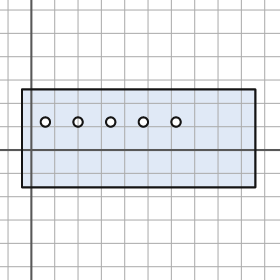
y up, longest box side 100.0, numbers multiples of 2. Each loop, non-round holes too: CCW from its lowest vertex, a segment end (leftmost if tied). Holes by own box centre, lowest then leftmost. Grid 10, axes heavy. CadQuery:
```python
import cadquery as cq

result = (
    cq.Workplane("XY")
    .moveTo(-4.0, -16.0)
    .lineTo(96.0, -16.0)
    .lineTo(96.0, 26.0)
    .lineTo(-4.0, 26.0)
    .close()
    .moveTo(6.0, 12.0)
    .circle(2.0)
    .moveTo(20.0, 12.0)
    .circle(2.0)
    .moveTo(34.0, 12.0)
    .circle(2.0)
    .moveTo(48.0, 12.0)
    .circle(2.0)
    .moveTo(62.0, 12.0)
    .circle(2.0)
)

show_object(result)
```